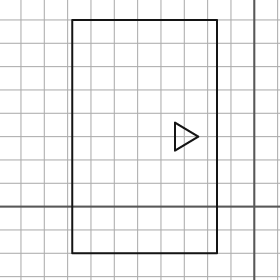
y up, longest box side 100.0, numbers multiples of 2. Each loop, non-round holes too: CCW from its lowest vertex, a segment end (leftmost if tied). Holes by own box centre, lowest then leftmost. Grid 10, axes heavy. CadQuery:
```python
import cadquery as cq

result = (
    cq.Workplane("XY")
    .moveTo(-78.0, -20.0)
    .lineTo(-16.0, -20.0)
    .lineTo(-16.0, 80.0)
    .lineTo(-78.0, 80.0)
    .close()
    .moveTo(-34.0, 24.0)
    .lineTo(-24.0, 30.0)
    .lineTo(-34.0, 36.0)
    .close()
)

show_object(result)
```